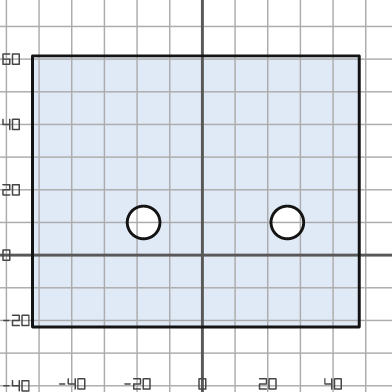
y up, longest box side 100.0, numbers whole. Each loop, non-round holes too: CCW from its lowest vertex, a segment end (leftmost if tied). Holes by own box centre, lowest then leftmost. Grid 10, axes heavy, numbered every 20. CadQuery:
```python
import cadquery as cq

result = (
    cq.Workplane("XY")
    .moveTo(-52.0, -22.0)
    .lineTo(48.0, -22.0)
    .lineTo(48.0, 61.0)
    .lineTo(-52.0, 61.0)
    .close()
    .moveTo(-18.0, 10.0)
    .circle(5.0)
    .moveTo(26.0, 10.0)
    .circle(5.0)
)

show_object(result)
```